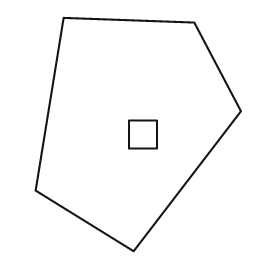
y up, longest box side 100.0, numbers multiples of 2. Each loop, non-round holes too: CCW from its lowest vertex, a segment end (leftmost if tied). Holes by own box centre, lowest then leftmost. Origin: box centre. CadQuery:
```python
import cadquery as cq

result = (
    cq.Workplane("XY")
    .moveTo(-2.0, -50.0)
    .lineTo(44.0, 10.0)
    .lineTo(24.0, 48.0)
    .lineTo(-32.0, 50.0)
    .lineTo(-44.0, -24.0)
    .close()
    .moveTo(-4.0, -6.0)
    .lineTo(8.0, -6.0)
    .lineTo(8.0, 6.0)
    .lineTo(-4.0, 6.0)
    .close()
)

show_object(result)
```